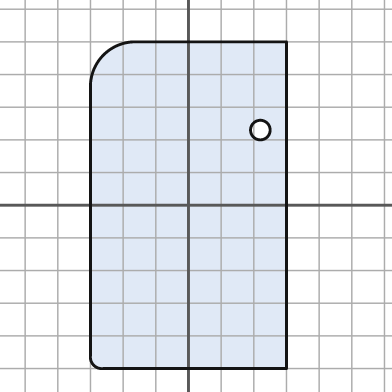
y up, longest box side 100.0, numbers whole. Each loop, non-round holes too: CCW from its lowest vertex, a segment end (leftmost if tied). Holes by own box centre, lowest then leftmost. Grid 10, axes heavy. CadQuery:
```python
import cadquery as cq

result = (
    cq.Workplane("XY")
    .moveTo(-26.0, -50.0)
    .lineTo(30.0, -50.0)
    .lineTo(30.0, 50.0)
    .lineTo(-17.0, 50.0)
    .threePointArc((-26.0, 46.0), (-30.0, 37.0))
    .lineTo(-30.0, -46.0)
    .threePointArc((-29.0, -49.0), (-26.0, -50.0))
    .close()
    .moveTo(22.0, 23.0)
    .circle(3.0)
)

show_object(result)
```